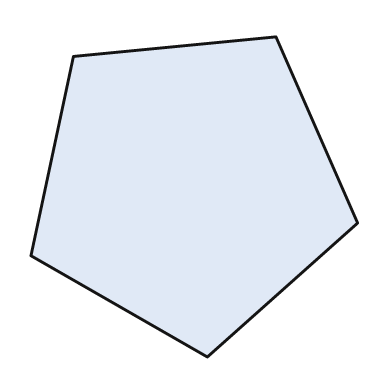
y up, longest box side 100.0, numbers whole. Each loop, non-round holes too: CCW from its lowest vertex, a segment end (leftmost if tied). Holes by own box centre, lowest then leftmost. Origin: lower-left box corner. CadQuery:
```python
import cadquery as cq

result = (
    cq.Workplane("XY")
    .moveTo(54.0, 0.0)
    .lineTo(100.0, 41.0)
    .lineTo(75.0, 98.0)
    .lineTo(13.0, 92.0)
    .lineTo(0.0, 31.0)
    .close()
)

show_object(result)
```